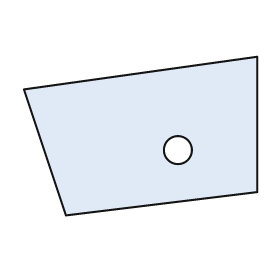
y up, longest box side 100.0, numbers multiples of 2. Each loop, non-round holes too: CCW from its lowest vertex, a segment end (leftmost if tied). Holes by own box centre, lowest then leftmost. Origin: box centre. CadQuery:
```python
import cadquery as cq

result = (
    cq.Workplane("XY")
    .moveTo(-32.0, -34.0)
    .lineTo(50.0, -24.0)
    .lineTo(50.0, 34.0)
    .lineTo(-50.0, 20.0)
    .close()
    .moveTo(16.0, -6.0)
    .circle(6.0)
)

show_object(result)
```